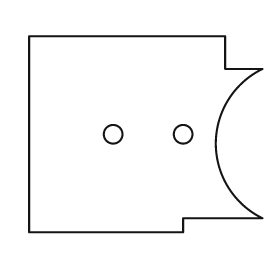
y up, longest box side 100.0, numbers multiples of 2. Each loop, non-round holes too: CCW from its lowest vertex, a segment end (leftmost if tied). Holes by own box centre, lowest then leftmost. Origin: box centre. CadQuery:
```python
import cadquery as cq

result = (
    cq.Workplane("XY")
    .moveTo(-50.0, -42.0)
    .lineTo(16.0, -42.0)
    .lineTo(16.0, -36.0)
    .lineTo(50.0, -36.0)
    .threePointArc((30.0, -4.0), (50.0, 28.0))
    .lineTo(34.0, 28.0)
    .lineTo(34.0, 42.0)
    .lineTo(-50.0, 42.0)
    .close()
    .moveTo(-14.0, 0.0)
    .circle(4.0)
    .moveTo(16.0, 0.0)
    .circle(4.0)
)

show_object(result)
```